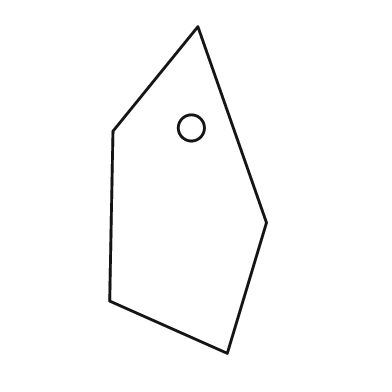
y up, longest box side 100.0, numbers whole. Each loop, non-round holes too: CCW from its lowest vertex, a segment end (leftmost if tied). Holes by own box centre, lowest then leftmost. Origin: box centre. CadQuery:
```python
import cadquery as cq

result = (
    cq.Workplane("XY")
    .moveTo(12.0, -50.0)
    .lineTo(24.0, -10.0)
    .lineTo(3.0, 50.0)
    .lineTo(-23.0, 18.0)
    .lineTo(-24.0, -34.0)
    .close()
    .moveTo(1.0, 19.0)
    .circle(4.0)
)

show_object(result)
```